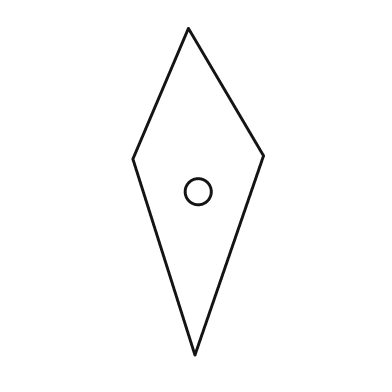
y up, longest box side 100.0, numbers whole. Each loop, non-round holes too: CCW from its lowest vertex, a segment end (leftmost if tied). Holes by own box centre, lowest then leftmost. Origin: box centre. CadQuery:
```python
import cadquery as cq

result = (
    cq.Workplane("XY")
    .moveTo(-1.0, -50.0)
    .lineTo(20.0, 11.0)
    .lineTo(-3.0, 50.0)
    .lineTo(-20.0, 10.0)
    .close()
    .moveTo(0.0, 0.0)
    .circle(4.0)
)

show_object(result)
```